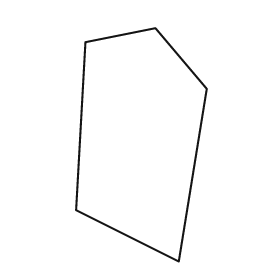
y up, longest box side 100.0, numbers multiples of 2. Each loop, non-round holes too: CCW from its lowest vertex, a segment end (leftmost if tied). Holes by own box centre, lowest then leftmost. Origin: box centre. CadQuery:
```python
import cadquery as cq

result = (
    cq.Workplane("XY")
    .moveTo(16.0, -50.0)
    .lineTo(28.0, 24.0)
    .lineTo(6.0, 50.0)
    .lineTo(-24.0, 44.0)
    .lineTo(-28.0, -28.0)
    .close()
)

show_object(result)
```